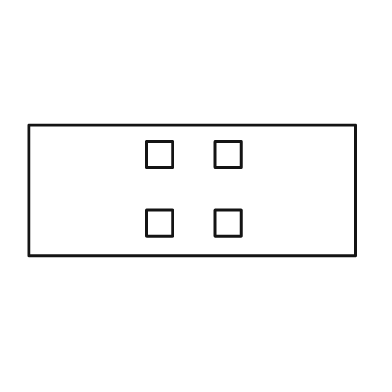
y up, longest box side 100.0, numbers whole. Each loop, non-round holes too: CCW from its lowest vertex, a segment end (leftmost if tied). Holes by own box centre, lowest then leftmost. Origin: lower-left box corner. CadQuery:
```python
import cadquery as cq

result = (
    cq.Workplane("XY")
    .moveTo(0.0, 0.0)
    .lineTo(100.0, 0.0)
    .lineTo(100.0, 40.0)
    .lineTo(0.0, 40.0)
    .close()
    .moveTo(36.0, 6.0)
    .lineTo(44.0, 6.0)
    .lineTo(44.0, 14.0)
    .lineTo(36.0, 14.0)
    .close()
    .moveTo(57.0, 6.0)
    .lineTo(65.0, 6.0)
    .lineTo(65.0, 14.0)
    .lineTo(57.0, 14.0)
    .close()
    .moveTo(36.0, 27.0)
    .lineTo(44.0, 27.0)
    .lineTo(44.0, 35.0)
    .lineTo(36.0, 35.0)
    .close()
    .moveTo(57.0, 27.0)
    .lineTo(65.0, 27.0)
    .lineTo(65.0, 35.0)
    .lineTo(57.0, 35.0)
    .close()
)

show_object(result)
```